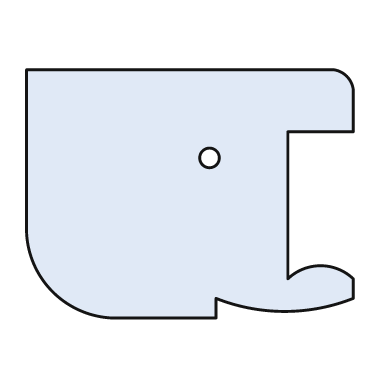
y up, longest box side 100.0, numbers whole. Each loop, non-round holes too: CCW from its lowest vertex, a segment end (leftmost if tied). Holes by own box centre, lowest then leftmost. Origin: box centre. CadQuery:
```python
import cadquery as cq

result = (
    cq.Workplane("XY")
    .moveTo(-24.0, -38.0)
    .lineTo(8.0, -38.0)
    .lineTo(8.0, -32.0)
    .threePointArc((29.0, -36.0), (50.0, -32.0))
    .lineTo(50.0, -26.0)
    .threePointArc((40.0, -22.0), (30.0, -26.0))
    .lineTo(30.0, 19.0)
    .lineTo(50.0, 19.0)
    .lineTo(50.0, 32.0)
    .threePointArc((48.0, 36.0), (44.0, 38.0))
    .lineTo(-50.0, 38.0)
    .lineTo(-50.0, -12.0)
    .threePointArc((-42.0, -30.0), (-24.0, -38.0))
    .close()
    .moveTo(6.0, 11.0)
    .circle(3.0)
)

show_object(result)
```